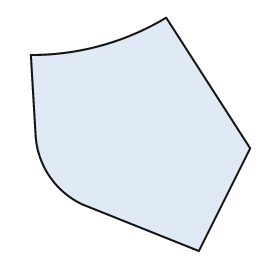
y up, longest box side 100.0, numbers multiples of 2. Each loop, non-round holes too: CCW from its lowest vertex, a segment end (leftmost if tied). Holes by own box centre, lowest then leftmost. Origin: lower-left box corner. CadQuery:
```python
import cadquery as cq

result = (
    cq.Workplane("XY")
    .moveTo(72.0, 0.0)
    .lineTo(94.0, 44.0)
    .lineTo(58.0, 100.0)
    .threePointArc((30.0, 88.0), (0.0, 84.0))
    .lineTo(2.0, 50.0)
    .threePointArc((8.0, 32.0), (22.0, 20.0))
    .close()
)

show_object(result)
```